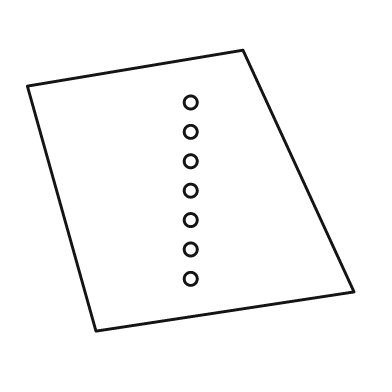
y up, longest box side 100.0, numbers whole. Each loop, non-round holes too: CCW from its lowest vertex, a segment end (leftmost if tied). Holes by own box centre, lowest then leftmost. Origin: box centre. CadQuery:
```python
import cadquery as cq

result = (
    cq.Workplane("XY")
    .moveTo(-29.0, -43.0)
    .lineTo(50.0, -31.0)
    .lineTo(16.0, 43.0)
    .lineTo(-50.0, 32.0)
    .close()
    .moveTo(0.0, -27.0)
    .circle(2.0)
    .moveTo(0.0, -18.0)
    .circle(2.0)
    .moveTo(0.0, -9.0)
    .circle(2.0)
    .moveTo(0.0, 0.0)
    .circle(2.0)
    .moveTo(0.0, 9.0)
    .circle(2.0)
    .moveTo(0.0, 18.0)
    .circle(2.0)
    .moveTo(0.0, 27.0)
    .circle(2.0)
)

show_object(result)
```